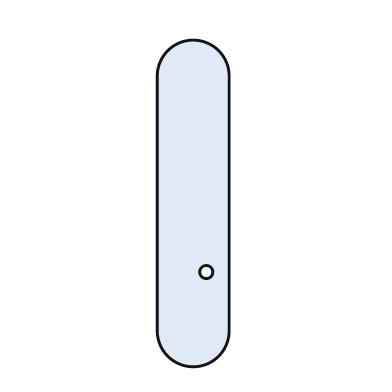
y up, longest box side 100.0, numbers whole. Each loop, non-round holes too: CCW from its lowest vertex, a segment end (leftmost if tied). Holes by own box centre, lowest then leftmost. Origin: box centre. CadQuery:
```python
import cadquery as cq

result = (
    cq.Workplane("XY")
    .moveTo(-11.0, -39.0)
    .threePointArc((0.0, -50.0), (11.0, -39.0))
    .lineTo(11.0, 39.0)
    .threePointArc((0.0, 50.0), (-11.0, 39.0))
    .close()
    .moveTo(4.0, -21.0)
    .circle(2.0)
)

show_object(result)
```